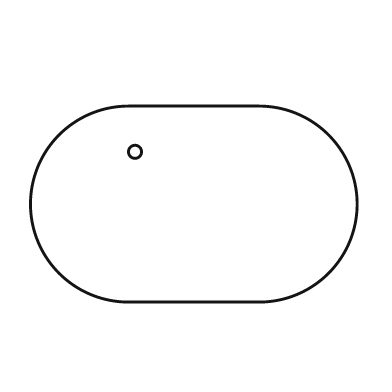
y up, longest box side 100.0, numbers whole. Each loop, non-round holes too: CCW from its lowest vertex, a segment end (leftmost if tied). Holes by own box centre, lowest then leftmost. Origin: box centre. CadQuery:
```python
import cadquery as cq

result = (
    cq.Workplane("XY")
    .moveTo(-20.0, -30.0)
    .lineTo(20.0, -30.0)
    .threePointArc((50.0, 0.0), (20.0, 30.0))
    .lineTo(-20.0, 30.0)
    .threePointArc((-50.0, 0.0), (-20.0, -30.0))
    .close()
    .moveTo(-18.0, 16.0)
    .circle(2.0)
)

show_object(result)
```